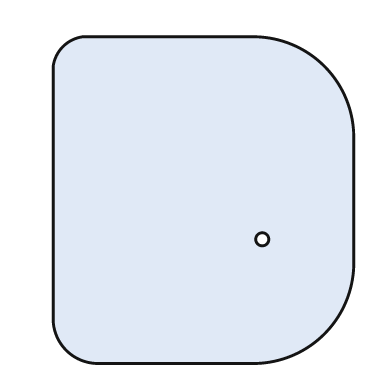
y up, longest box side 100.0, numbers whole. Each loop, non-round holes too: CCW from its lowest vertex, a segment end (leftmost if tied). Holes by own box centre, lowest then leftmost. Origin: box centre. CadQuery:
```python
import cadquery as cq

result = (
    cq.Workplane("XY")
    .moveTo(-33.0, -50.0)
    .lineTo(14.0, -50.0)
    .threePointArc((37.0, -41.0), (46.0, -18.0))
    .lineTo(46.0, 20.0)
    .threePointArc((37.0, 41.0), (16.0, 50.0))
    .lineTo(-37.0, 50.0)
    .threePointArc((-43.0, 47.0), (-46.0, 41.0))
    .lineTo(-46.0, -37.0)
    .threePointArc((-42.0, -46.0), (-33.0, -50.0))
    .close()
    .moveTo(18.0, -12.0)
    .circle(2.0)
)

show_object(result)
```